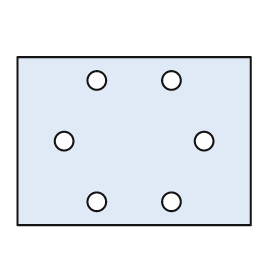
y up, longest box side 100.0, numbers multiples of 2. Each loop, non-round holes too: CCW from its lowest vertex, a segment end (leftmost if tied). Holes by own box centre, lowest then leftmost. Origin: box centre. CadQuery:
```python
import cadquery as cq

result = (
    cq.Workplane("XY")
    .moveTo(-50.0, -36.0)
    .lineTo(50.0, -36.0)
    .lineTo(50.0, 36.0)
    .lineTo(-50.0, 36.0)
    .close()
    .moveTo(-16.0, -26.0)
    .circle(4.0)
    .moveTo(16.0, -26.0)
    .circle(4.0)
    .moveTo(-30.0, 0.0)
    .circle(4.0)
    .moveTo(30.0, 0.0)
    .circle(4.0)
    .moveTo(-16.0, 26.0)
    .circle(4.0)
    .moveTo(16.0, 26.0)
    .circle(4.0)
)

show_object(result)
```